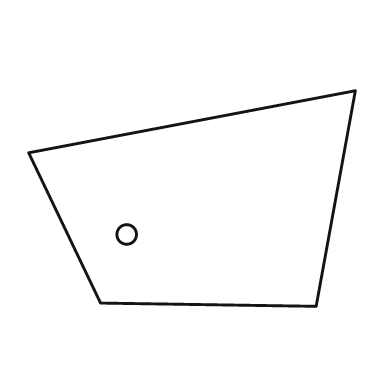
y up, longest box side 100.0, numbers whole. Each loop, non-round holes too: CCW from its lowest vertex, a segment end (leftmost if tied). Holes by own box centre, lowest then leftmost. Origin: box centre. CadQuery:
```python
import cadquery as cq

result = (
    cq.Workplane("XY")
    .moveTo(38.0, -33.0)
    .lineTo(50.0, 33.0)
    .lineTo(-50.0, 14.0)
    .lineTo(-28.0, -32.0)
    .close()
    .moveTo(-20.0, -11.0)
    .circle(3.0)
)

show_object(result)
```